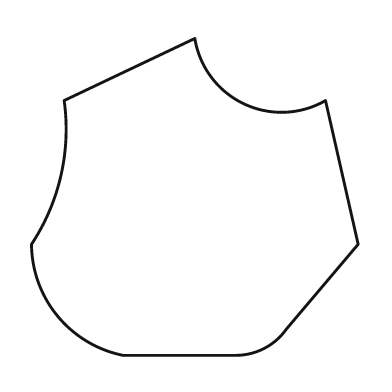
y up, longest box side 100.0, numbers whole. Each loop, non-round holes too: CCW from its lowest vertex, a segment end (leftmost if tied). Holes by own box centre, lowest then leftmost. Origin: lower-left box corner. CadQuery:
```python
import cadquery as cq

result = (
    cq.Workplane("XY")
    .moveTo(28.0, 0.0)
    .lineTo(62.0, 0.0)
    .threePointArc((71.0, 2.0), (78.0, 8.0))
    .lineTo(100.0, 34.0)
    .lineTo(90.0, 78.0)
    .threePointArc((65.0, 77.0), (50.0, 97.0))
    .lineTo(10.0, 78.0)
    .threePointArc((9.0, 55.0), (0.0, 34.0))
    .threePointArc((8.0, 12.0), (28.0, 0.0))
    .close()
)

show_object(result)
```